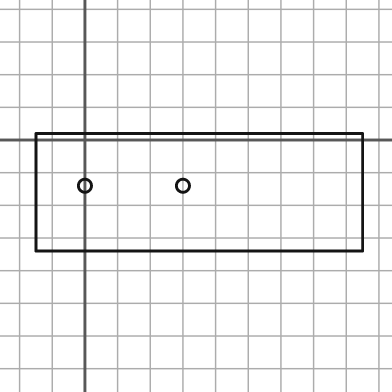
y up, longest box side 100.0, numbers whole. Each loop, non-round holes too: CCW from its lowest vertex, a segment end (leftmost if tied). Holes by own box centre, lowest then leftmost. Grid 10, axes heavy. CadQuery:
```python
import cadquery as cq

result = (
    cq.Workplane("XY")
    .moveTo(-15.0, -34.0)
    .lineTo(85.0, -34.0)
    .lineTo(85.0, 2.0)
    .lineTo(-15.0, 2.0)
    .close()
    .moveTo(0.0, -14.0)
    .circle(2.0)
    .moveTo(30.0, -14.0)
    .circle(2.0)
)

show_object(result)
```